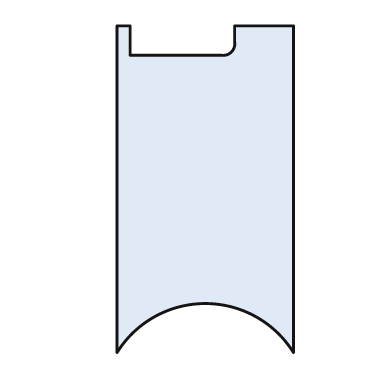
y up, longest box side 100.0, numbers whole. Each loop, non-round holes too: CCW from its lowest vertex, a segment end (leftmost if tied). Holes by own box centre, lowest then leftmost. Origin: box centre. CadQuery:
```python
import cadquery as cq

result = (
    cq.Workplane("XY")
    .moveTo(-27.0, -50.0)
    .threePointArc((0.0, -35.0), (27.0, -50.0))
    .lineTo(27.0, 50.0)
    .lineTo(9.0, 50.0)
    .lineTo(9.0, 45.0)
    .threePointArc((8.0, 42.0), (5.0, 41.0))
    .lineTo(-23.0, 41.0)
    .lineTo(-23.0, 50.0)
    .lineTo(-27.0, 50.0)
    .close()
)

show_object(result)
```